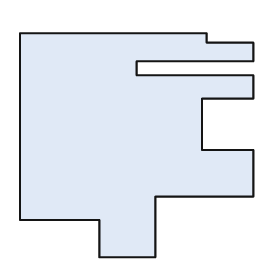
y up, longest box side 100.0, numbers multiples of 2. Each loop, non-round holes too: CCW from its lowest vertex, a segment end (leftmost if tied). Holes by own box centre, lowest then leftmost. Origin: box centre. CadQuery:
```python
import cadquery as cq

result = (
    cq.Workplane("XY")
    .moveTo(-16.0, -48.0)
    .lineTo(8.0, -48.0)
    .lineTo(8.0, -22.0)
    .lineTo(50.0, -22.0)
    .lineTo(50.0, -2.0)
    .lineTo(28.0, -2.0)
    .lineTo(28.0, 20.0)
    .lineTo(50.0, 20.0)
    .lineTo(50.0, 30.0)
    .lineTo(0.0, 30.0)
    .lineTo(0.0, 36.0)
    .lineTo(50.0, 36.0)
    .lineTo(50.0, 44.0)
    .lineTo(30.0, 44.0)
    .lineTo(30.0, 48.0)
    .lineTo(-50.0, 48.0)
    .lineTo(-50.0, -32.0)
    .lineTo(-16.0, -32.0)
    .close()
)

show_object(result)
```